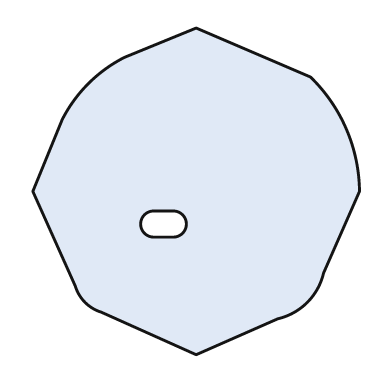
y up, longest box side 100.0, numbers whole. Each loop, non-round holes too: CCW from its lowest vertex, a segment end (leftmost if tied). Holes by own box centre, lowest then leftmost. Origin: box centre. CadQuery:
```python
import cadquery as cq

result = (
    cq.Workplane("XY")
    .moveTo(0.0, -50.0)
    .lineTo(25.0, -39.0)
    .threePointArc((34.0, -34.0), (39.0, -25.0))
    .lineTo(50.0, 0.0)
    .threePointArc((46.0, 19.0), (35.0, 35.0))
    .lineTo(0.0, 50.0)
    .lineTo(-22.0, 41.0)
    .threePointArc((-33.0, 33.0), (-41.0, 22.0))
    .lineTo(-50.0, 0.0)
    .lineTo(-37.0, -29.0)
    .threePointArc((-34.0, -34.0), (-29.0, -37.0))
    .close()
    .moveTo(-13.0, -14.0)
    .lineTo(-7.0, -14.0)
    .threePointArc((-3.0, -10.0), (-7.0, -6.0))
    .lineTo(-13.0, -6.0)
    .threePointArc((-17.0, -10.0), (-13.0, -14.0))
    .close()
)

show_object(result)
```